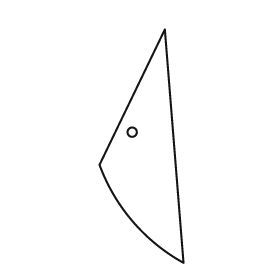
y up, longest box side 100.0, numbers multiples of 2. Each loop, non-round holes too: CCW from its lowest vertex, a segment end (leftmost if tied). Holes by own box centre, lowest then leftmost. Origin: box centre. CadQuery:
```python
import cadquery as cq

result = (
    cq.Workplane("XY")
    .moveTo(18.0, -50.0)
    .lineTo(10.0, 50.0)
    .lineTo(-18.0, -8.0)
    .threePointArc((-4.0, -32.0), (18.0, -50.0))
    .close()
    .moveTo(-4.0, 6.0)
    .circle(2.0)
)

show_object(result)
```